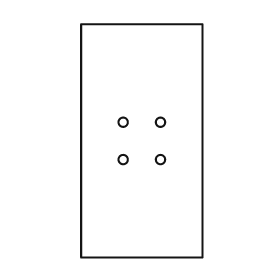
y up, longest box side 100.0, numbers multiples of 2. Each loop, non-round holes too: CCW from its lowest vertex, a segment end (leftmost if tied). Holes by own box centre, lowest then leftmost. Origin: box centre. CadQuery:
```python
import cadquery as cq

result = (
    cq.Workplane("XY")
    .moveTo(-26.0, -50.0)
    .lineTo(26.0, -50.0)
    .lineTo(26.0, 50.0)
    .lineTo(-26.0, 50.0)
    .close()
    .moveTo(-8.0, -8.0)
    .circle(2.0)
    .moveTo(8.0, -8.0)
    .circle(2.0)
    .moveTo(-8.0, 8.0)
    .circle(2.0)
    .moveTo(8.0, 8.0)
    .circle(2.0)
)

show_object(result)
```